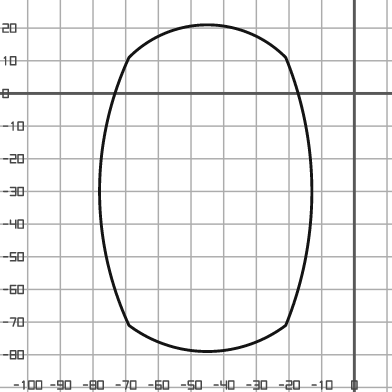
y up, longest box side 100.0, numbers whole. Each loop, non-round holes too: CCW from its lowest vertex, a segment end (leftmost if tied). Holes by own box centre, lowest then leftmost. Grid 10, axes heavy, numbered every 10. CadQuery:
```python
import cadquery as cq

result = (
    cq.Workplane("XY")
    .moveTo(-69.0, -71.0)
    .threePointArc((-45.0, -79.0), (-21.0, -71.0))
    .threePointArc((-13.0, -30.0), (-21.0, 11.0))
    .threePointArc((-45.0, 21.0), (-69.0, 11.0))
    .threePointArc((-78.0, -30.0), (-69.0, -71.0))
    .close()
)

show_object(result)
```